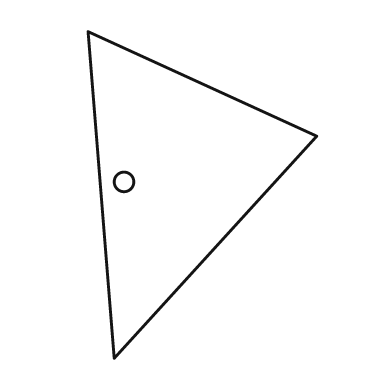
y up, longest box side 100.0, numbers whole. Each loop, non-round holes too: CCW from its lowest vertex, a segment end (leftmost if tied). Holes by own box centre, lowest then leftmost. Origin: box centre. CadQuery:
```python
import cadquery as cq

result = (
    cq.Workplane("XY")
    .moveTo(-27.0, -50.0)
    .lineTo(35.0, 18.0)
    .lineTo(-35.0, 50.0)
    .close()
    .moveTo(-24.0, 4.0)
    .circle(3.0)
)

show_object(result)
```